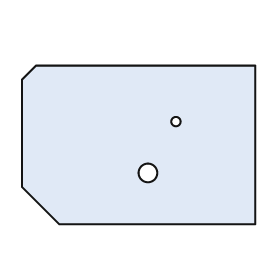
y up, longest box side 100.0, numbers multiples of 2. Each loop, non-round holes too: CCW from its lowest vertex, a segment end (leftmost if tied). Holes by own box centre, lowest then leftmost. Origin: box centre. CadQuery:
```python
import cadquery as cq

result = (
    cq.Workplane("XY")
    .moveTo(-34.0, -34.0)
    .lineTo(50.0, -34.0)
    .lineTo(50.0, 34.0)
    .lineTo(-44.0, 34.0)
    .lineTo(-50.0, 28.0)
    .lineTo(-50.0, -18.0)
    .close()
    .moveTo(4.0, -12.0)
    .circle(4.0)
    .moveTo(16.0, 10.0)
    .circle(2.0)
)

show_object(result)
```